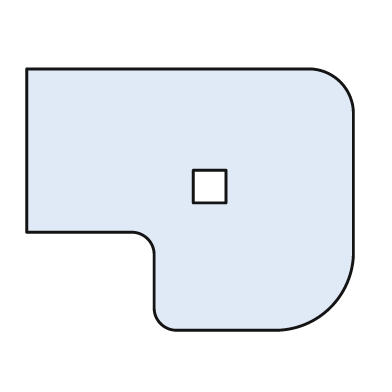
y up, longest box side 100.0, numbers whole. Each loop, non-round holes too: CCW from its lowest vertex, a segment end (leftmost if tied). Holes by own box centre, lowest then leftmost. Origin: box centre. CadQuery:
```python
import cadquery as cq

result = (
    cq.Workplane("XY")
    .moveTo(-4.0, -40.0)
    .lineTo(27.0, -40.0)
    .threePointArc((43.0, -33.0), (50.0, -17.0))
    .lineTo(50.0, 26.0)
    .threePointArc((46.0, 36.0), (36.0, 40.0))
    .lineTo(-50.0, 40.0)
    .lineTo(-50.0, -10.0)
    .lineTo(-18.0, -10.0)
    .threePointArc((-13.0, -12.0), (-11.0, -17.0))
    .lineTo(-11.0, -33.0)
    .threePointArc((-9.0, -38.0), (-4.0, -40.0))
    .close()
    .moveTo(1.0, -1.0)
    .lineTo(11.0, -1.0)
    .lineTo(11.0, 9.0)
    .lineTo(1.0, 9.0)
    .close()
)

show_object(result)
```